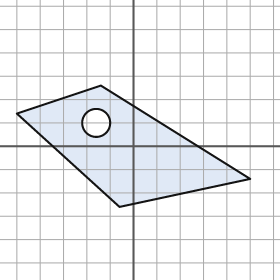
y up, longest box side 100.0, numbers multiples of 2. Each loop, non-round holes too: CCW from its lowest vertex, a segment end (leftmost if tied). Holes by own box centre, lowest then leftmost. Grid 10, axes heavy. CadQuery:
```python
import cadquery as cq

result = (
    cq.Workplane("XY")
    .moveTo(-6.0, -26.0)
    .lineTo(50.0, -14.0)
    .lineTo(-14.0, 26.0)
    .lineTo(-50.0, 14.0)
    .close()
    .moveTo(-16.0, 10.0)
    .circle(6.0)
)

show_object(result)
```